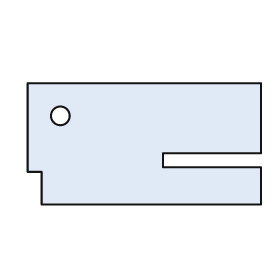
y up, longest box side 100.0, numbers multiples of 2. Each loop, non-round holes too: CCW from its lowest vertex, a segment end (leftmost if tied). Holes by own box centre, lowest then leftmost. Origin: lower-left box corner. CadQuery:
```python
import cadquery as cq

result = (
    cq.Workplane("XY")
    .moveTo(6.0, 0.0)
    .lineTo(100.0, 0.0)
    .lineTo(100.0, 16.0)
    .lineTo(58.0, 16.0)
    .lineTo(58.0, 22.0)
    .lineTo(100.0, 22.0)
    .lineTo(100.0, 52.0)
    .lineTo(0.0, 52.0)
    .lineTo(0.0, 14.0)
    .lineTo(6.0, 14.0)
    .close()
    .moveTo(14.0, 38.0)
    .circle(4.0)
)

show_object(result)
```